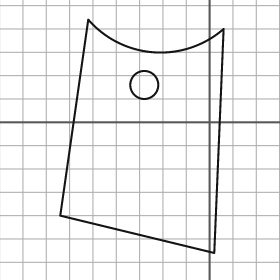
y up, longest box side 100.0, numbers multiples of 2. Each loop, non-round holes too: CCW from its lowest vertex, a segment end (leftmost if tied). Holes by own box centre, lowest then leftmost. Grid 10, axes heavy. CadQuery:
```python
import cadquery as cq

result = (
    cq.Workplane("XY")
    .moveTo(2.0, -56.0)
    .lineTo(6.0, 40.0)
    .threePointArc((-24.0, 30.0), (-52.0, 44.0))
    .lineTo(-64.0, -40.0)
    .close()
    .moveTo(-28.0, 16.0)
    .circle(6.0)
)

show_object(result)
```